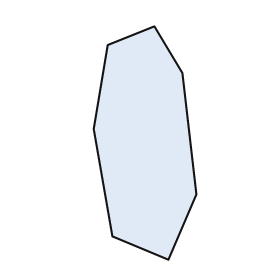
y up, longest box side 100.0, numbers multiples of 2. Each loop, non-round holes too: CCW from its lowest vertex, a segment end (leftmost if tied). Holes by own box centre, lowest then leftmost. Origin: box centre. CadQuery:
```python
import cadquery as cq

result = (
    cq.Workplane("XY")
    .moveTo(10.0, -50.0)
    .lineTo(22.0, -22.0)
    .lineTo(16.0, 30.0)
    .lineTo(4.0, 50.0)
    .lineTo(-16.0, 42.0)
    .lineTo(-22.0, 6.0)
    .lineTo(-14.0, -40.0)
    .close()
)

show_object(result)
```